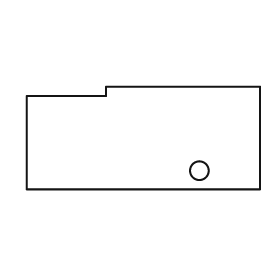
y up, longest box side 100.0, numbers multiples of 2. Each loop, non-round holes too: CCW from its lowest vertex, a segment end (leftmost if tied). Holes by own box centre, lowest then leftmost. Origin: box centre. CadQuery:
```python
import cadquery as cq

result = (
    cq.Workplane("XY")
    .moveTo(-50.0, -22.0)
    .lineTo(50.0, -22.0)
    .lineTo(50.0, 22.0)
    .lineTo(-16.0, 22.0)
    .lineTo(-16.0, 18.0)
    .lineTo(-50.0, 18.0)
    .close()
    .moveTo(24.0, -14.0)
    .circle(4.0)
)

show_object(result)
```